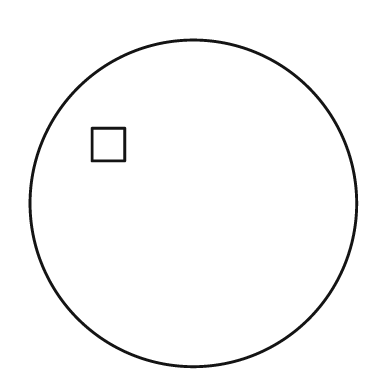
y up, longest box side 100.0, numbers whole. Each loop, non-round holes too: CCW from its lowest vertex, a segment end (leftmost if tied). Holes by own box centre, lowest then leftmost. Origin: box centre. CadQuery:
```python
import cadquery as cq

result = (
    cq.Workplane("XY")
    .moveTo(0.0, 0.0)
    .circle(50.0)
    .moveTo(-31.0, 13.0)
    .lineTo(-21.0, 13.0)
    .lineTo(-21.0, 23.0)
    .lineTo(-31.0, 23.0)
    .close()
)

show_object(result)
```